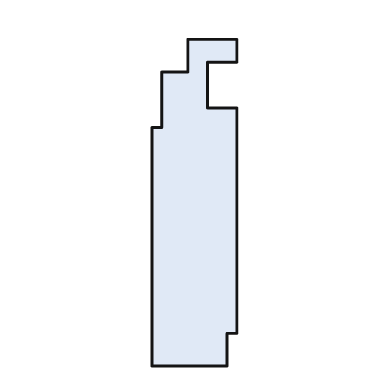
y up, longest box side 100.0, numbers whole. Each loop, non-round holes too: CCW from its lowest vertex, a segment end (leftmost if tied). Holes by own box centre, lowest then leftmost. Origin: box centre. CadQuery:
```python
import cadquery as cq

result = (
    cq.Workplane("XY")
    .moveTo(-13.0, -50.0)
    .lineTo(10.0, -50.0)
    .lineTo(10.0, -40.0)
    .lineTo(13.0, -40.0)
    .lineTo(13.0, 29.0)
    .lineTo(4.0, 29.0)
    .lineTo(4.0, 43.0)
    .lineTo(13.0, 43.0)
    .lineTo(13.0, 50.0)
    .lineTo(-2.0, 50.0)
    .lineTo(-2.0, 40.0)
    .lineTo(-10.0, 40.0)
    .lineTo(-10.0, 23.0)
    .lineTo(-13.0, 23.0)
    .close()
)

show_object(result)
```